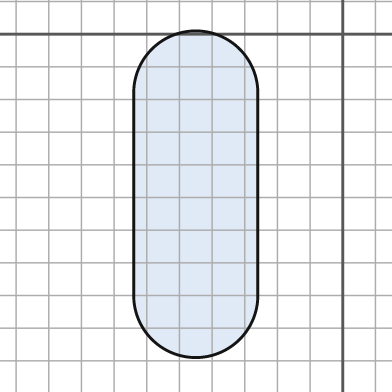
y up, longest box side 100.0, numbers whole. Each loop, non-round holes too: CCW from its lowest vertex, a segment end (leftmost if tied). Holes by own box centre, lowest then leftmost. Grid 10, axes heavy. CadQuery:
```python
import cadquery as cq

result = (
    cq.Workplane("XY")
    .moveTo(-64.0, -80.0)
    .threePointArc((-45.0, -99.0), (-26.0, -80.0))
    .lineTo(-26.0, -18.0)
    .threePointArc((-45.0, 1.0), (-64.0, -18.0))
    .close()
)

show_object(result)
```